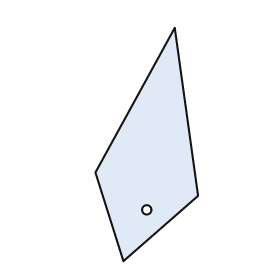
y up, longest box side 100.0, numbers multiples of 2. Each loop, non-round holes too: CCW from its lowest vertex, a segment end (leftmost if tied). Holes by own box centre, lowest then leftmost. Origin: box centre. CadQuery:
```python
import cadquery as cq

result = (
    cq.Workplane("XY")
    .moveTo(-10.0, -50.0)
    .lineTo(22.0, -22.0)
    .lineTo(12.0, 50.0)
    .lineTo(-22.0, -12.0)
    .close()
    .moveTo(0.0, -28.0)
    .circle(2.0)
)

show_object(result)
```